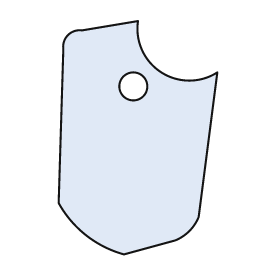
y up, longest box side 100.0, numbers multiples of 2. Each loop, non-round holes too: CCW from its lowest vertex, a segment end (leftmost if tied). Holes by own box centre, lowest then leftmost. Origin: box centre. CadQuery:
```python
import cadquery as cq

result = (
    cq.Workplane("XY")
    .moveTo(-6.0, -50.0)
    .lineTo(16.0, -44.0)
    .threePointArc((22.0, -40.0), (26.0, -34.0))
    .lineTo(34.0, 28.0)
    .threePointArc((10.0, 28.0), (0.0, 50.0))
    .lineTo(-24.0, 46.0)
    .threePointArc((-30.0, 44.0), (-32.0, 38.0))
    .lineTo(-34.0, -28.0)
    .threePointArc((-22.0, -42.0), (-6.0, -50.0))
    .close()
    .moveTo(-2.0, 22.0)
    .circle(6.0)
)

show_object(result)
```